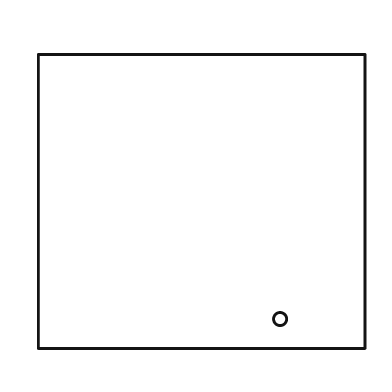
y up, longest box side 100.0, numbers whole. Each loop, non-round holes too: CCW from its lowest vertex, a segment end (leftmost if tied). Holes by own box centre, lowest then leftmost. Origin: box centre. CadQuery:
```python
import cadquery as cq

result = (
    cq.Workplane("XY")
    .moveTo(-50.0, -45.0)
    .lineTo(50.0, -45.0)
    .lineTo(50.0, 45.0)
    .lineTo(-50.0, 45.0)
    .close()
    .moveTo(24.0, -36.0)
    .circle(2.0)
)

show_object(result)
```